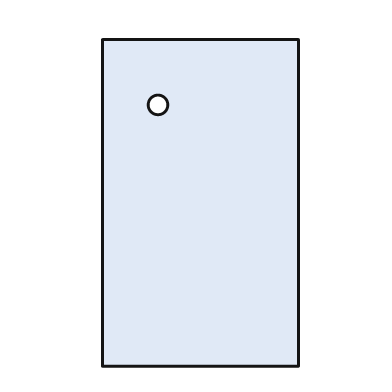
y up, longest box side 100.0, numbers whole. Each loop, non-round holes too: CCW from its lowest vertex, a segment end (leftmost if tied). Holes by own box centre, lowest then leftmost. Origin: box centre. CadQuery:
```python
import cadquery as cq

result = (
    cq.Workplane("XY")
    .moveTo(-30.0, -50.0)
    .lineTo(30.0, -50.0)
    .lineTo(30.0, 50.0)
    .lineTo(-30.0, 50.0)
    .close()
    .moveTo(-13.0, 30.0)
    .circle(3.0)
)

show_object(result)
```